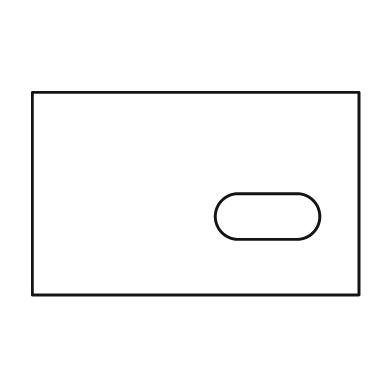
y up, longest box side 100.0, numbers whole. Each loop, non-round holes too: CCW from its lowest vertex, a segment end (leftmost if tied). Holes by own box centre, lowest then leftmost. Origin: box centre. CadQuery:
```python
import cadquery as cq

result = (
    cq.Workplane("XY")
    .moveTo(-50.0, -31.0)
    .lineTo(50.0, -31.0)
    .lineTo(50.0, 31.0)
    .lineTo(-50.0, 31.0)
    .close()
    .moveTo(13.0, -14.0)
    .lineTo(31.0, -14.0)
    .threePointArc((38.0, -7.0), (31.0, 0.0))
    .lineTo(13.0, 0.0)
    .threePointArc((6.0, -7.0), (13.0, -14.0))
    .close()
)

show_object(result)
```